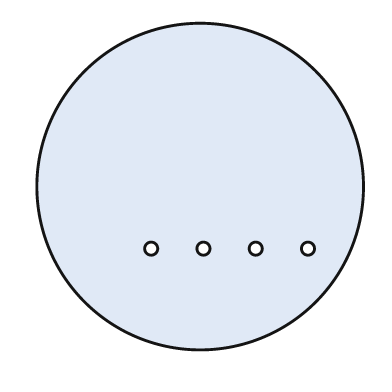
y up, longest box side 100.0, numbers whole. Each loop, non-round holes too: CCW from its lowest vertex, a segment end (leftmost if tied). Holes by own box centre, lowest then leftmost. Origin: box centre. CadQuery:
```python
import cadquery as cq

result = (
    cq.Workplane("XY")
    .moveTo(0.0, 0.0)
    .circle(50.0)
    .moveTo(-15.0, -19.0)
    .circle(2.0)
    .moveTo(1.0, -19.0)
    .circle(2.0)
    .moveTo(17.0, -19.0)
    .circle(2.0)
    .moveTo(33.0, -19.0)
    .circle(2.0)
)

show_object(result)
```